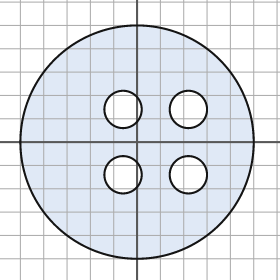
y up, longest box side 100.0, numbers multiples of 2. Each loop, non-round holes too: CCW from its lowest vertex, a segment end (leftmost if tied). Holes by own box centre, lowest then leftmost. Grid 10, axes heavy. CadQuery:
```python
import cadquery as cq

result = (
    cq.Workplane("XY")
    .moveTo(0.0, 0.0)
    .circle(50.0)
    .moveTo(-6.0, -14.0)
    .circle(8.0)
    .moveTo(22.0, -14.0)
    .circle(8.0)
    .moveTo(-6.0, 14.0)
    .circle(8.0)
    .moveTo(22.0, 14.0)
    .circle(8.0)
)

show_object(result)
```